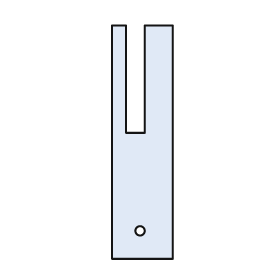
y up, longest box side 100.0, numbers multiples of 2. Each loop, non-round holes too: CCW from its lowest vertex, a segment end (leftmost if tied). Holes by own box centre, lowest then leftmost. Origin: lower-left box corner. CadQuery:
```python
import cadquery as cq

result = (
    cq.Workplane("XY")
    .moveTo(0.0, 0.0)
    .lineTo(26.0, 0.0)
    .lineTo(26.0, 100.0)
    .lineTo(14.0, 100.0)
    .lineTo(14.0, 54.0)
    .lineTo(6.0, 54.0)
    .lineTo(6.0, 100.0)
    .lineTo(0.0, 100.0)
    .close()
    .moveTo(12.0, 12.0)
    .circle(2.0)
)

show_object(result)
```